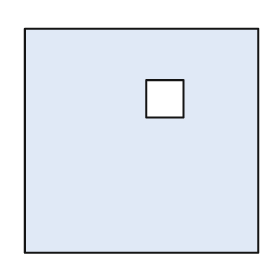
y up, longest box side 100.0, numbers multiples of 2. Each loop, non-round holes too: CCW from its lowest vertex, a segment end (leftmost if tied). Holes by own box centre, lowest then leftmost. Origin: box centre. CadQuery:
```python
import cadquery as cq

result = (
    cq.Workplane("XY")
    .moveTo(-50.0, -48.0)
    .lineTo(50.0, -48.0)
    .lineTo(50.0, 48.0)
    .lineTo(-50.0, 48.0)
    .close()
    .moveTo(2.0, 10.0)
    .lineTo(18.0, 10.0)
    .lineTo(18.0, 26.0)
    .lineTo(2.0, 26.0)
    .close()
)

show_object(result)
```